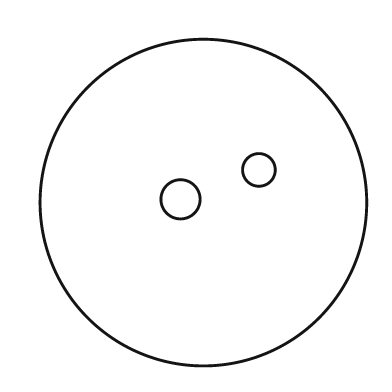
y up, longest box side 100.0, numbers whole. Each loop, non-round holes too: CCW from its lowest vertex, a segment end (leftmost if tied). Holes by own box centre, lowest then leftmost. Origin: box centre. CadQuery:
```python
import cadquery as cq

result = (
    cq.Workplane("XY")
    .moveTo(0.0, 0.0)
    .circle(50.0)
    .moveTo(-7.0, 1.0)
    .circle(6.0)
    .moveTo(17.0, 10.0)
    .circle(5.0)
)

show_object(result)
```